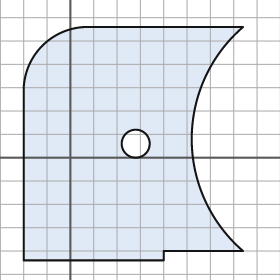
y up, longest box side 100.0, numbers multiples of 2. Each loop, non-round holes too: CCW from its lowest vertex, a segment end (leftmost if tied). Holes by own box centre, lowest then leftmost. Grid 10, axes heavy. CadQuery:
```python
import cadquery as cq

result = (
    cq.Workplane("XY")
    .moveTo(-20.0, -44.0)
    .lineTo(40.0, -44.0)
    .lineTo(40.0, -40.0)
    .lineTo(74.0, -40.0)
    .threePointArc((52.0, 8.0), (74.0, 56.0))
    .lineTo(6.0, 56.0)
    .threePointArc((-12.0, 48.0), (-20.0, 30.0))
    .close()
    .moveTo(28.0, 6.0)
    .circle(6.0)
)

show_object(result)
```